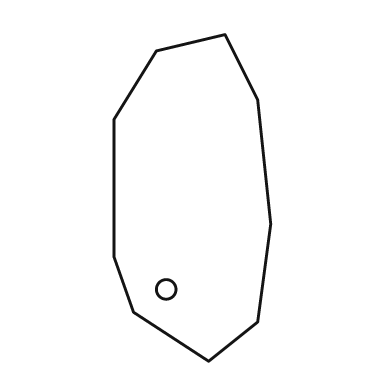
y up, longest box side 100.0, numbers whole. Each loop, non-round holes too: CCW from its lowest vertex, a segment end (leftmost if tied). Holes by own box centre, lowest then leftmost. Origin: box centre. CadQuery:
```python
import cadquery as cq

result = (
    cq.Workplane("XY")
    .moveTo(5.0, -50.0)
    .lineTo(20.0, -38.0)
    .lineTo(24.0, -8.0)
    .lineTo(20.0, 30.0)
    .lineTo(10.0, 50.0)
    .lineTo(-11.0, 45.0)
    .lineTo(-24.0, 24.0)
    .lineTo(-24.0, -18.0)
    .lineTo(-18.0, -35.0)
    .close()
    .moveTo(-8.0, -28.0)
    .circle(3.0)
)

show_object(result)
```